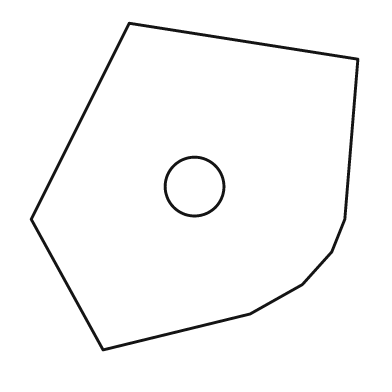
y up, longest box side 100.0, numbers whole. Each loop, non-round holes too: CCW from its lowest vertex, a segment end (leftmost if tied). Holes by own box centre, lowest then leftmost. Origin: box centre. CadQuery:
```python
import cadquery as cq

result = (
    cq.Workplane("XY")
    .moveTo(-28.0, -50.0)
    .lineTo(17.0, -39.0)
    .lineTo(33.0, -30.0)
    .lineTo(42.0, -20.0)
    .lineTo(46.0, -10.0)
    .lineTo(50.0, 39.0)
    .lineTo(-20.0, 50.0)
    .lineTo(-50.0, -10.0)
    .close()
    .moveTo(0.0, 0.0)
    .circle(9.0)
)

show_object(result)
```